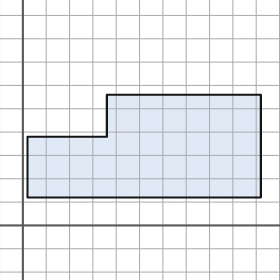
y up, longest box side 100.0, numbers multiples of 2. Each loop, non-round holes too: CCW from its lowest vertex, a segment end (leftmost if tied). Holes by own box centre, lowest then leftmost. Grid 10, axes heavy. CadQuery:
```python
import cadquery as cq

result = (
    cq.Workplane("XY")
    .moveTo(2.0, 12.0)
    .lineTo(102.0, 12.0)
    .lineTo(102.0, 56.0)
    .lineTo(36.0, 56.0)
    .lineTo(36.0, 38.0)
    .lineTo(2.0, 38.0)
    .close()
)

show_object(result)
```